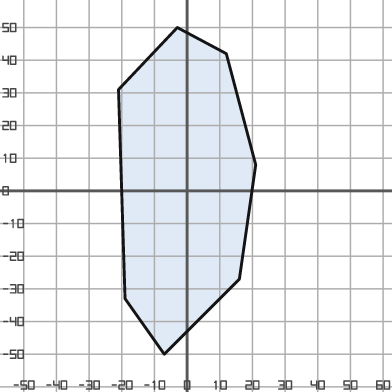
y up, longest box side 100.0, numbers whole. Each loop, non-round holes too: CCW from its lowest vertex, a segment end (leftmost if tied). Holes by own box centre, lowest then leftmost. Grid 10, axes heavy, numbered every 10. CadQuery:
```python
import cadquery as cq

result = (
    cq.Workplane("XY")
    .moveTo(-7.0, -50.0)
    .lineTo(16.0, -27.0)
    .lineTo(21.0, 8.0)
    .lineTo(12.0, 42.0)
    .lineTo(-3.0, 50.0)
    .lineTo(-21.0, 31.0)
    .lineTo(-19.0, -33.0)
    .close()
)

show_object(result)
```